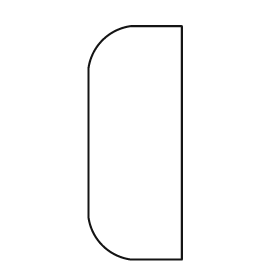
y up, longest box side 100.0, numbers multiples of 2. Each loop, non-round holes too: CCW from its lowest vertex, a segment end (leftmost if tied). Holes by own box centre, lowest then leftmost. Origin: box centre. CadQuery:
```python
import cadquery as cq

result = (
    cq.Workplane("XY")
    .moveTo(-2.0, -50.0)
    .lineTo(20.0, -50.0)
    .lineTo(20.0, 50.0)
    .lineTo(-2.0, 50.0)
    .threePointArc((-14.0, 44.0), (-20.0, 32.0))
    .lineTo(-20.0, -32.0)
    .threePointArc((-14.0, -44.0), (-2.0, -50.0))
    .close()
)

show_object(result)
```